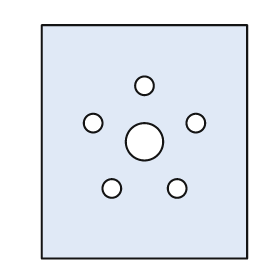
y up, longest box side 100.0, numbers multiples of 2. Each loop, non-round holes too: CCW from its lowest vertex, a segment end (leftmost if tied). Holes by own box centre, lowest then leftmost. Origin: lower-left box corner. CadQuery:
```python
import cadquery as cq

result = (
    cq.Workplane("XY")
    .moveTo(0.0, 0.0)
    .lineTo(88.0, 0.0)
    .lineTo(88.0, 100.0)
    .lineTo(0.0, 100.0)
    .close()
    .moveTo(30.0, 30.0)
    .circle(4.0)
    .moveTo(58.0, 30.0)
    .circle(4.0)
    .moveTo(44.0, 50.0)
    .circle(8.0)
    .moveTo(22.0, 58.0)
    .circle(4.0)
    .moveTo(66.0, 58.0)
    .circle(4.0)
    .moveTo(44.0, 74.0)
    .circle(4.0)
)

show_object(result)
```